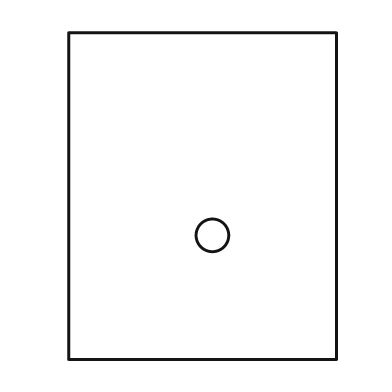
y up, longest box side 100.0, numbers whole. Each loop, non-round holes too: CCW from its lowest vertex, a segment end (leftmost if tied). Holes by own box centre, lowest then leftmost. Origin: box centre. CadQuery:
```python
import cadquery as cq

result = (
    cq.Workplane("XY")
    .moveTo(-41.0, -50.0)
    .lineTo(41.0, -50.0)
    .lineTo(41.0, 50.0)
    .lineTo(-41.0, 50.0)
    .close()
    .moveTo(3.0, -12.0)
    .circle(5.0)
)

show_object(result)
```